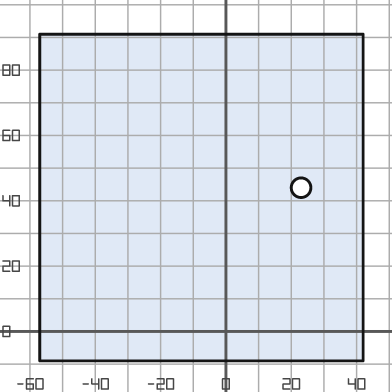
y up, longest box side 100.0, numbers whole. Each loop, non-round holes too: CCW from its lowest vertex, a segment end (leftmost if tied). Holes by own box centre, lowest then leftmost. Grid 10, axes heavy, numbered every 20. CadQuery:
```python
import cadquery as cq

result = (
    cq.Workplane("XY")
    .moveTo(-57.0, -9.0)
    .lineTo(42.0, -9.0)
    .lineTo(42.0, 91.0)
    .lineTo(-57.0, 91.0)
    .close()
    .moveTo(23.0, 44.0)
    .circle(3.0)
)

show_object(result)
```